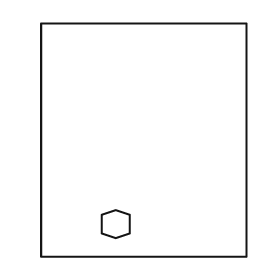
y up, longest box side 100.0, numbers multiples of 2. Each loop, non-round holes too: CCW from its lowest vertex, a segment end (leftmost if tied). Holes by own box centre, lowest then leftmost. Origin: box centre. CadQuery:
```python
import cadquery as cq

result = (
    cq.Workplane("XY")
    .moveTo(-44.0, -50.0)
    .lineTo(44.0, -50.0)
    .lineTo(44.0, 50.0)
    .lineTo(-44.0, 50.0)
    .close()
    .moveTo(-12.0, -42.0)
    .lineTo(-6.0, -40.0)
    .lineTo(-6.0, -32.0)
    .lineTo(-12.0, -30.0)
    .lineTo(-18.0, -32.0)
    .lineTo(-18.0, -40.0)
    .close()
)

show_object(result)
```